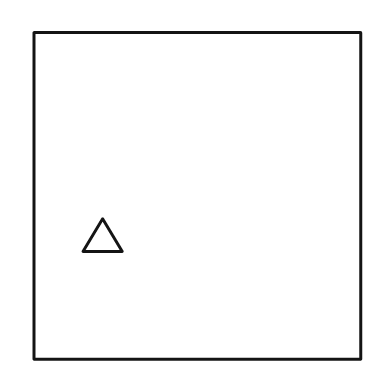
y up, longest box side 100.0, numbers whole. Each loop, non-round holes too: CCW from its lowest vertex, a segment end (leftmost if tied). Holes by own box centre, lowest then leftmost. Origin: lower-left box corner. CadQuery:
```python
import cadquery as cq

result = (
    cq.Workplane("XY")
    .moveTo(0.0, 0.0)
    .lineTo(100.0, 0.0)
    .lineTo(100.0, 100.0)
    .lineTo(0.0, 100.0)
    .close()
    .moveTo(15.0, 33.0)
    .lineTo(27.0, 33.0)
    .lineTo(21.0, 43.0)
    .close()
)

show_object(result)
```